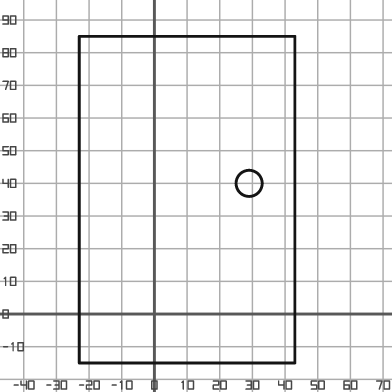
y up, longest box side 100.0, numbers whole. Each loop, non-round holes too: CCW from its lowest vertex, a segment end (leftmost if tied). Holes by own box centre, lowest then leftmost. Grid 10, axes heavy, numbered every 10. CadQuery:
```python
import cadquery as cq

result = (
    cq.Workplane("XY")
    .moveTo(-23.0, -15.0)
    .lineTo(43.0, -15.0)
    .lineTo(43.0, 85.0)
    .lineTo(-23.0, 85.0)
    .close()
    .moveTo(29.0, 40.0)
    .circle(4.0)
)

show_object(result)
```